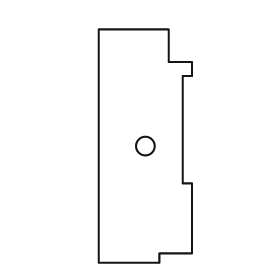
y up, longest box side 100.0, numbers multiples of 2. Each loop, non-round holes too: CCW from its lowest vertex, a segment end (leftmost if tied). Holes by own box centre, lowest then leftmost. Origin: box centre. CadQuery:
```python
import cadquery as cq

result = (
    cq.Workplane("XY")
    .moveTo(-20.0, -50.0)
    .lineTo(6.0, -50.0)
    .lineTo(6.0, -46.0)
    .lineTo(20.0, -46.0)
    .lineTo(20.0, -16.0)
    .lineTo(16.0, -16.0)
    .lineTo(16.0, 30.0)
    .lineTo(20.0, 30.0)
    .lineTo(20.0, 36.0)
    .lineTo(10.0, 36.0)
    .lineTo(10.0, 50.0)
    .lineTo(-20.0, 50.0)
    .close()
    .moveTo(0.0, 0.0)
    .circle(4.0)
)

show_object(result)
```